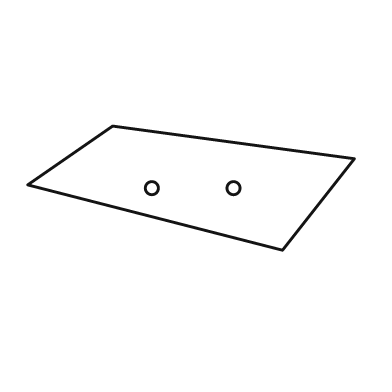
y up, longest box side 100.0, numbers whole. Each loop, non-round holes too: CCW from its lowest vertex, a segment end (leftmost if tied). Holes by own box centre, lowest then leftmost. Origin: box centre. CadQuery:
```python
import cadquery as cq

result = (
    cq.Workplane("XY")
    .moveTo(28.0, -19.0)
    .lineTo(50.0, 9.0)
    .lineTo(-24.0, 19.0)
    .lineTo(-50.0, 1.0)
    .close()
    .moveTo(-12.0, 0.0)
    .circle(2.0)
    .moveTo(13.0, 0.0)
    .circle(2.0)
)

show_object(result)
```